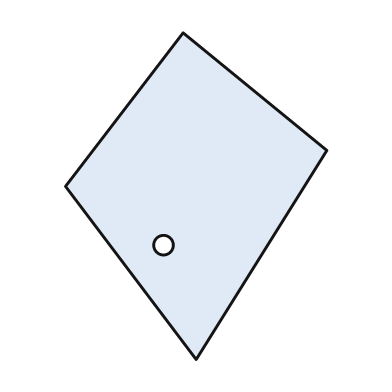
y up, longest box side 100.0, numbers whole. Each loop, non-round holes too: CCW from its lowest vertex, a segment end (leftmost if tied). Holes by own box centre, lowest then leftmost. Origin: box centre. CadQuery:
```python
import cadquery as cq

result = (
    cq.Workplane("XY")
    .moveTo(0.0, -50.0)
    .lineTo(40.0, 14.0)
    .lineTo(-4.0, 50.0)
    .lineTo(-40.0, 3.0)
    .close()
    .moveTo(-10.0, -15.0)
    .circle(3.0)
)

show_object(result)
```